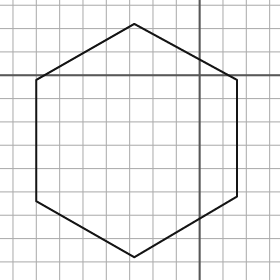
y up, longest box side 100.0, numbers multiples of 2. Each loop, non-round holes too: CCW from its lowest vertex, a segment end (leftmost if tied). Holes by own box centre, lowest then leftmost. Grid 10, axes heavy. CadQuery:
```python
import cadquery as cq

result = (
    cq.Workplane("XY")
    .moveTo(-28.0, -78.0)
    .lineTo(16.0, -52.0)
    .lineTo(16.0, -2.0)
    .lineTo(-28.0, 22.0)
    .lineTo(-70.0, -2.0)
    .lineTo(-70.0, -54.0)
    .close()
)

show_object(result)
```